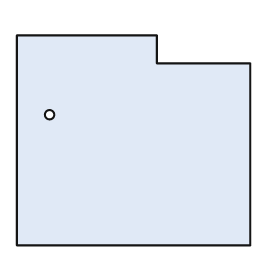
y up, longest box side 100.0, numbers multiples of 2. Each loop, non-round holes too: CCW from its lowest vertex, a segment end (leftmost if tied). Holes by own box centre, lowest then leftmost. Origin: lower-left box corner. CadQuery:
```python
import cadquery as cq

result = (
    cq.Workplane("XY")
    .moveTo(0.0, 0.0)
    .lineTo(100.0, 0.0)
    .lineTo(100.0, 78.0)
    .lineTo(60.0, 78.0)
    .lineTo(60.0, 90.0)
    .lineTo(0.0, 90.0)
    .close()
    .moveTo(14.0, 56.0)
    .circle(2.0)
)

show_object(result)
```